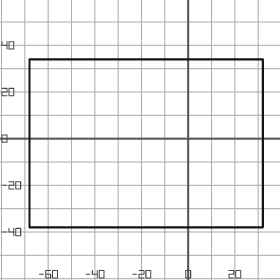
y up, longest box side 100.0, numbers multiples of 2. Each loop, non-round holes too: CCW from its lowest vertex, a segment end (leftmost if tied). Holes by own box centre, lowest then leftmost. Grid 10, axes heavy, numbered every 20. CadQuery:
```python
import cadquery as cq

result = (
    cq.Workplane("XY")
    .moveTo(-68.0, -38.0)
    .lineTo(32.0, -38.0)
    .lineTo(32.0, 34.0)
    .lineTo(-68.0, 34.0)
    .close()
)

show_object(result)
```